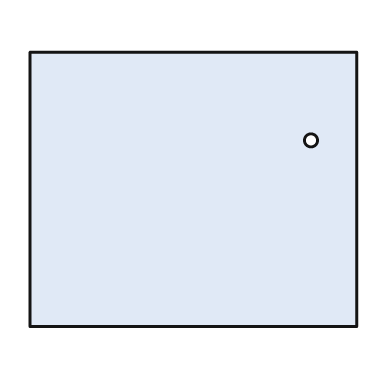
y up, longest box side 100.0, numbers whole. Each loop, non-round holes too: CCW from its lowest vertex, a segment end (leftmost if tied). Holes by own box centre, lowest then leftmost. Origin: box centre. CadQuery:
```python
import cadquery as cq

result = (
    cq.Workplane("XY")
    .moveTo(-50.0, -42.0)
    .lineTo(50.0, -42.0)
    .lineTo(50.0, 42.0)
    .lineTo(-50.0, 42.0)
    .close()
    .moveTo(36.0, 15.0)
    .circle(2.0)
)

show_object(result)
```